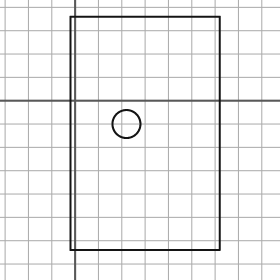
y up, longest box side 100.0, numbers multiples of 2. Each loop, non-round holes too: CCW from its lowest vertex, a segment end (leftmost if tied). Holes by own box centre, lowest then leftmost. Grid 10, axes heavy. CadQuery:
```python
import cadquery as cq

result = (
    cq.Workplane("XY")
    .moveTo(-2.0, -64.0)
    .lineTo(62.0, -64.0)
    .lineTo(62.0, 36.0)
    .lineTo(-2.0, 36.0)
    .close()
    .moveTo(22.0, -10.0)
    .circle(6.0)
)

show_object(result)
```